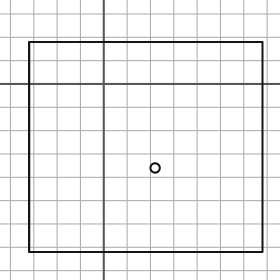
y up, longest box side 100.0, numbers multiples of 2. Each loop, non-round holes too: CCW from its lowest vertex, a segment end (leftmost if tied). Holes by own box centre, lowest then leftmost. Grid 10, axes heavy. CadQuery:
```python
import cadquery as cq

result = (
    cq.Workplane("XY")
    .moveTo(-32.0, -72.0)
    .lineTo(68.0, -72.0)
    .lineTo(68.0, 18.0)
    .lineTo(-32.0, 18.0)
    .close()
    .moveTo(22.0, -36.0)
    .circle(2.0)
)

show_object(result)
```